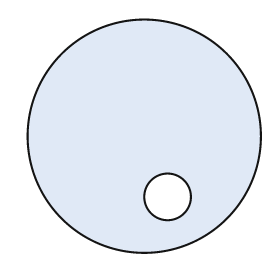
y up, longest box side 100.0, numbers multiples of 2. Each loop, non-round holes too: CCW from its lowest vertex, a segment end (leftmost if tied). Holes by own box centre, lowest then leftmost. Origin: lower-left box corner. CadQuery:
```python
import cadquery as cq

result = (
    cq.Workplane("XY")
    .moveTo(50.0, 50.0)
    .circle(50.0)
    .moveTo(60.0, 24.0)
    .circle(10.0)
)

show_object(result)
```